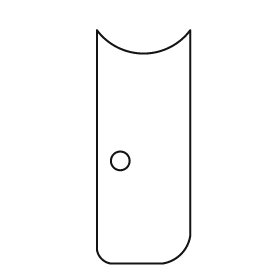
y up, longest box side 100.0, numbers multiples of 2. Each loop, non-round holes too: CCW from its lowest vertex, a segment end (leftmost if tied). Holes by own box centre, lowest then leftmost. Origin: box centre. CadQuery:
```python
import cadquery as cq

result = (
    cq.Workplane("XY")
    .moveTo(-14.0, -50.0)
    .lineTo(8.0, -50.0)
    .threePointArc((16.0, -46.0), (20.0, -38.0))
    .lineTo(20.0, 50.0)
    .threePointArc((0.0, 40.0), (-20.0, 50.0))
    .lineTo(-20.0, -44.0)
    .threePointArc((-18.0, -48.0), (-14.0, -50.0))
    .close()
    .moveTo(-10.0, -6.0)
    .circle(4.0)
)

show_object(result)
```